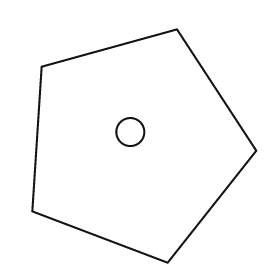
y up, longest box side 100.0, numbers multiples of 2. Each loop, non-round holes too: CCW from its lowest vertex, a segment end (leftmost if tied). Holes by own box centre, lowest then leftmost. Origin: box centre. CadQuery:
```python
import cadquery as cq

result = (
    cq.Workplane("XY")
    .moveTo(10.0, -50.0)
    .lineTo(48.0, -2.0)
    .lineTo(14.0, 50.0)
    .lineTo(-44.0, 34.0)
    .lineTo(-48.0, -28.0)
    .close()
    .moveTo(-6.0, 6.0)
    .circle(6.0)
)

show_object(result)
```